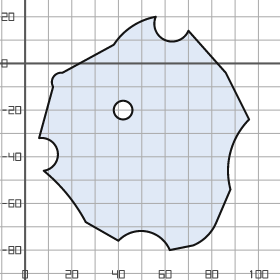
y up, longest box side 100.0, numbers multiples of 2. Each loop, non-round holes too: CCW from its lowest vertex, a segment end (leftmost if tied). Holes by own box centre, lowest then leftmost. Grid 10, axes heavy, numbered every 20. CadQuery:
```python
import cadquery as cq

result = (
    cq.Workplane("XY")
    .moveTo(62.0, -80.0)
    .lineTo(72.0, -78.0)
    .threePointArc((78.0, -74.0), (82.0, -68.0))
    .lineTo(88.0, -54.0)
    .threePointArc((88.0, -38.0), (96.0, -24.0))
    .lineTo(86.0, -4.0)
    .lineTo(70.0, 14.0)
    .threePointArc((60.0, 10.0), (56.0, 20.0))
    .threePointArc((46.0, 16.0), (38.0, 8.0))
    .lineTo(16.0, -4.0)
    .threePointArc((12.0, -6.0), (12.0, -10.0))
    .lineTo(6.0, -32.0)
    .threePointArc((14.0, -38.0), (8.0, -46.0))
    .threePointArc((18.0, -56.0), (26.0, -68.0))
    .lineTo(40.0, -76.0)
    .threePointArc((52.0, -72.0), (62.0, -80.0))
    .close()
    .moveTo(42.0, -20.0)
    .circle(4.0)
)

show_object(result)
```